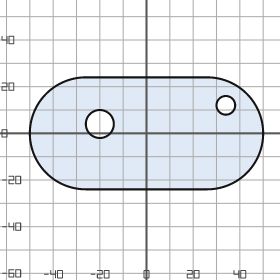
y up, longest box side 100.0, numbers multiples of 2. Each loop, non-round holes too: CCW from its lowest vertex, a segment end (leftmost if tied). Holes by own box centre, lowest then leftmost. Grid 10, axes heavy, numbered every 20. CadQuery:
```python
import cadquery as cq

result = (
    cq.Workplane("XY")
    .moveTo(-26.0, -24.0)
    .lineTo(26.0, -24.0)
    .threePointArc((50.0, 0.0), (26.0, 24.0))
    .lineTo(-26.0, 24.0)
    .threePointArc((-50.0, 0.0), (-26.0, -24.0))
    .close()
    .moveTo(-20.0, 4.0)
    .circle(6.0)
    .moveTo(34.0, 12.0)
    .circle(4.0)
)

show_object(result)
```